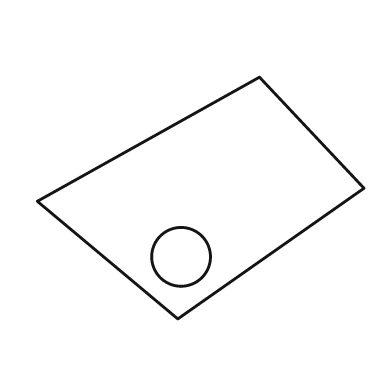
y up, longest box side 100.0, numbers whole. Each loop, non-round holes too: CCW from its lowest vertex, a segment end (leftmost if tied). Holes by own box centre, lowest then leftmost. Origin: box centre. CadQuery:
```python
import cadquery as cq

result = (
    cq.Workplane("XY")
    .moveTo(-7.0, -37.0)
    .lineTo(50.0, 3.0)
    .lineTo(18.0, 37.0)
    .lineTo(-50.0, -1.0)
    .close()
    .moveTo(-6.0, -18.0)
    .circle(9.0)
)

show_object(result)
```